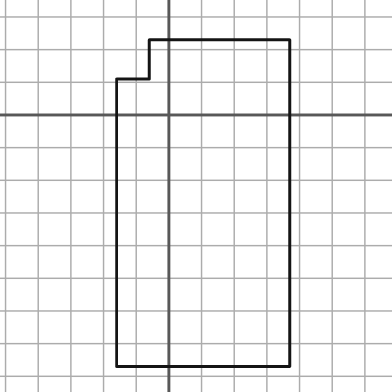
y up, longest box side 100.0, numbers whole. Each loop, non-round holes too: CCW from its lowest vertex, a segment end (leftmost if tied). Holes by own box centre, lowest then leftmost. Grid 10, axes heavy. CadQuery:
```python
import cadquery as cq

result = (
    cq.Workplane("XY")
    .moveTo(-16.0, -77.0)
    .lineTo(37.0, -77.0)
    .lineTo(37.0, 23.0)
    .lineTo(-6.0, 23.0)
    .lineTo(-6.0, 11.0)
    .lineTo(-16.0, 11.0)
    .close()
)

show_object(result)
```